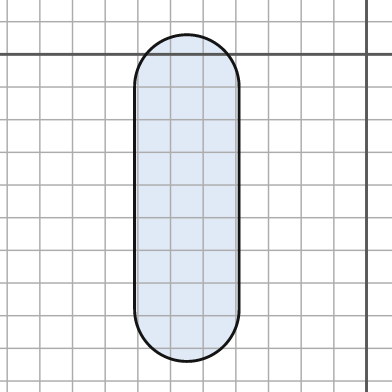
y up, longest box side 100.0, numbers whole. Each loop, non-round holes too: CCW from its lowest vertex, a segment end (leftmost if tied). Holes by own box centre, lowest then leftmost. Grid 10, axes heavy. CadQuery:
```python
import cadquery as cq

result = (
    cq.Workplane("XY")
    .moveTo(-71.0, -78.0)
    .threePointArc((-55.0, -94.0), (-39.0, -78.0))
    .lineTo(-39.0, -10.0)
    .threePointArc((-55.0, 6.0), (-71.0, -10.0))
    .close()
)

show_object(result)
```